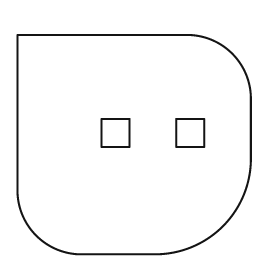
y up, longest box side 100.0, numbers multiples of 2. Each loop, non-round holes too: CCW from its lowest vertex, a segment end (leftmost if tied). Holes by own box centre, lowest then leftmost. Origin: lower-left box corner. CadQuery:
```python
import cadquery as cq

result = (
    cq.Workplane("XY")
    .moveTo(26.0, 0.0)
    .lineTo(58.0, 0.0)
    .threePointArc((88.0, 12.0), (100.0, 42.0))
    .lineTo(100.0, 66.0)
    .threePointArc((92.0, 86.0), (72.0, 94.0))
    .lineTo(0.0, 94.0)
    .lineTo(0.0, 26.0)
    .threePointArc((8.0, 8.0), (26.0, 0.0))
    .close()
    .moveTo(36.0, 46.0)
    .lineTo(48.0, 46.0)
    .lineTo(48.0, 58.0)
    .lineTo(36.0, 58.0)
    .close()
    .moveTo(68.0, 46.0)
    .lineTo(80.0, 46.0)
    .lineTo(80.0, 58.0)
    .lineTo(68.0, 58.0)
    .close()
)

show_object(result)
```